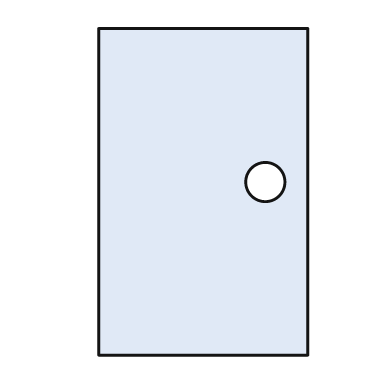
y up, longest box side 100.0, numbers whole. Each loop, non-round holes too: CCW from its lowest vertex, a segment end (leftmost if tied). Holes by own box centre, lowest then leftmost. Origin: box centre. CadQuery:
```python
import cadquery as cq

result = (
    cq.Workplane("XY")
    .moveTo(-32.0, -50.0)
    .lineTo(32.0, -50.0)
    .lineTo(32.0, 50.0)
    .lineTo(-32.0, 50.0)
    .close()
    .moveTo(19.0, 3.0)
    .circle(6.0)
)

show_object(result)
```